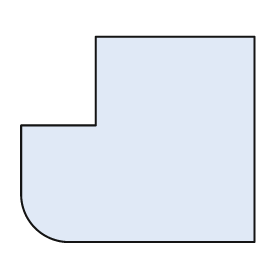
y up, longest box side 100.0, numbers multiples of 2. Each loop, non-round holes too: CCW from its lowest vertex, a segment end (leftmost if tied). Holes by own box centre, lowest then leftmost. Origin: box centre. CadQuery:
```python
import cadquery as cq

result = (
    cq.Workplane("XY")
    .moveTo(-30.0, -44.0)
    .lineTo(50.0, -44.0)
    .lineTo(50.0, 44.0)
    .lineTo(-18.0, 44.0)
    .lineTo(-18.0, 6.0)
    .lineTo(-50.0, 6.0)
    .lineTo(-50.0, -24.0)
    .threePointArc((-44.0, -38.0), (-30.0, -44.0))
    .close()
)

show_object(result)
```